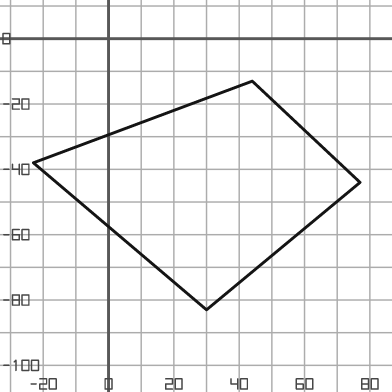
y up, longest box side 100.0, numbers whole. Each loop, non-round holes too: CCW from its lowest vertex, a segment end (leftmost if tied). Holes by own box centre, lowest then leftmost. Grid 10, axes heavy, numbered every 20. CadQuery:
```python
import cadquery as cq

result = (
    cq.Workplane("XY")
    .moveTo(30.0, -83.0)
    .lineTo(77.0, -44.0)
    .lineTo(44.0, -13.0)
    .lineTo(-23.0, -38.0)
    .close()
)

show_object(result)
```